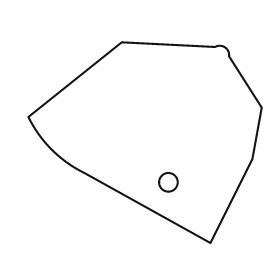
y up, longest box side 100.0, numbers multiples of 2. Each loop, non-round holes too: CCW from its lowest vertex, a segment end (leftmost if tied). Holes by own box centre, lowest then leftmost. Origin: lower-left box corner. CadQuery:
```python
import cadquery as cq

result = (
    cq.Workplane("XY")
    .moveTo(78.0, 0.0)
    .lineTo(96.0, 36.0)
    .lineTo(100.0, 58.0)
    .lineTo(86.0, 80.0)
    .threePointArc((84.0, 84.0), (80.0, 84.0))
    .lineTo(40.0, 86.0)
    .lineTo(0.0, 54.0)
    .threePointArc((10.0, 40.0), (24.0, 30.0))
    .close()
    .moveTo(60.0, 26.0)
    .circle(4.0)
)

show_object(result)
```